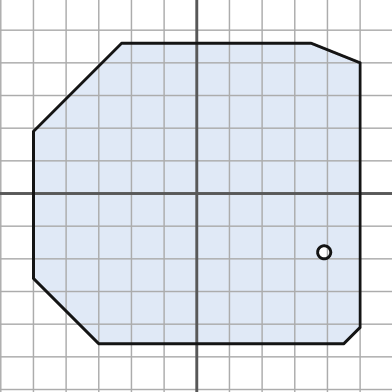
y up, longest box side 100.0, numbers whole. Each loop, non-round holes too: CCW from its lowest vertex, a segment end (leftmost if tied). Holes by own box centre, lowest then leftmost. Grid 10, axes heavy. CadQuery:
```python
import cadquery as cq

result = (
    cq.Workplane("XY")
    .moveTo(-30.0, -46.0)
    .lineTo(45.0, -46.0)
    .lineTo(50.0, -41.0)
    .lineTo(50.0, 40.0)
    .lineTo(35.0, 46.0)
    .lineTo(-23.0, 46.0)
    .lineTo(-50.0, 19.0)
    .lineTo(-50.0, -26.0)
    .close()
    .moveTo(39.0, -18.0)
    .circle(2.0)
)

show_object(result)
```